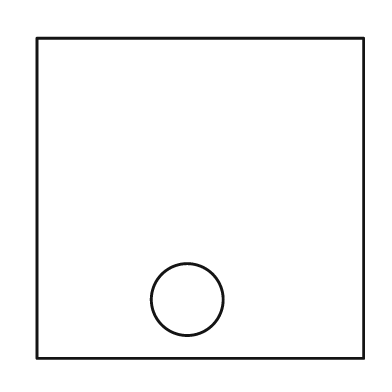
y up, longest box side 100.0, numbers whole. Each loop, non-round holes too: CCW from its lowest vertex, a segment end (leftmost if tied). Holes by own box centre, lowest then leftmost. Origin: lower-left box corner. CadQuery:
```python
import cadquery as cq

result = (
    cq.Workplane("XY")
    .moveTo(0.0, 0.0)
    .lineTo(100.0, 0.0)
    .lineTo(100.0, 98.0)
    .lineTo(0.0, 98.0)
    .close()
    .moveTo(46.0, 18.0)
    .circle(11.0)
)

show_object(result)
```